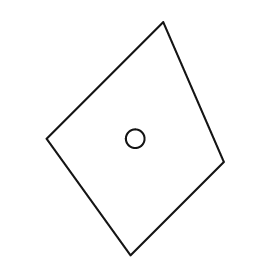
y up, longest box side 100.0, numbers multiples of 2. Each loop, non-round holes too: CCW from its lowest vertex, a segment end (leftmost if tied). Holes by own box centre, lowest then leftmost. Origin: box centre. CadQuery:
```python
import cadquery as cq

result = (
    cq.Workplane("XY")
    .moveTo(-2.0, -50.0)
    .lineTo(38.0, -10.0)
    .lineTo(12.0, 50.0)
    .lineTo(-38.0, 0.0)
    .close()
    .moveTo(0.0, 0.0)
    .circle(4.0)
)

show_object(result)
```